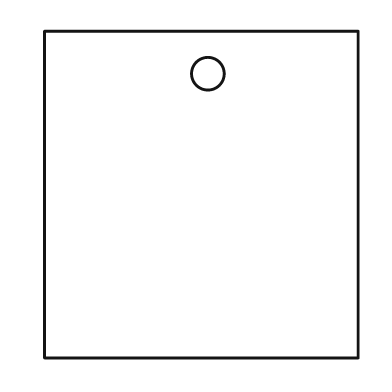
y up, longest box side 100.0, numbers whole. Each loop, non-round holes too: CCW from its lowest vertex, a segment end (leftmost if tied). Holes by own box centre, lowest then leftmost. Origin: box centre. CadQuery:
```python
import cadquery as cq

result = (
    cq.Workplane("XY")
    .moveTo(-48.0, -50.0)
    .lineTo(48.0, -50.0)
    .lineTo(48.0, 50.0)
    .lineTo(-48.0, 50.0)
    .close()
    .moveTo(2.0, 37.0)
    .circle(5.0)
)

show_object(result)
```